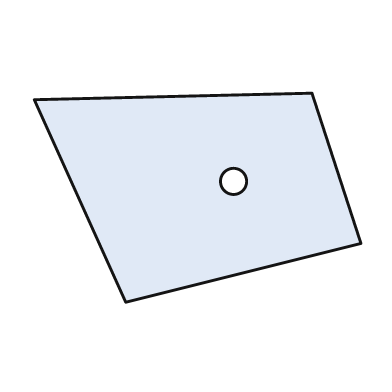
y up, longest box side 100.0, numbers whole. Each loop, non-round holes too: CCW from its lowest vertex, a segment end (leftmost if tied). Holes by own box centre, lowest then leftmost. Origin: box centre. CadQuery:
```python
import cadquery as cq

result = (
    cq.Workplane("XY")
    .moveTo(-22.0, -32.0)
    .lineTo(50.0, -14.0)
    .lineTo(35.0, 32.0)
    .lineTo(-50.0, 30.0)
    .close()
    .moveTo(11.0, 5.0)
    .circle(4.0)
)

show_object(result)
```